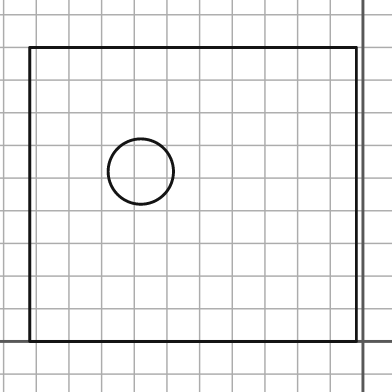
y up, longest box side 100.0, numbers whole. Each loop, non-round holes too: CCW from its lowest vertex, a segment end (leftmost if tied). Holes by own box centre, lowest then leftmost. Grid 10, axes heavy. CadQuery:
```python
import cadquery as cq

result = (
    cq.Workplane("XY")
    .moveTo(-102.0, 0.0)
    .lineTo(-2.0, 0.0)
    .lineTo(-2.0, 90.0)
    .lineTo(-102.0, 90.0)
    .close()
    .moveTo(-68.0, 52.0)
    .circle(10.0)
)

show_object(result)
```